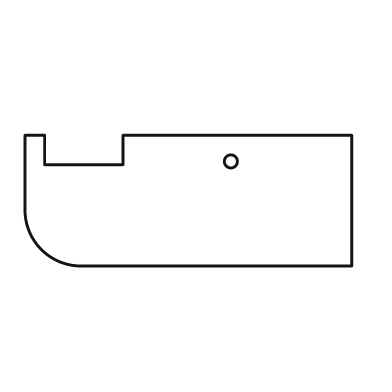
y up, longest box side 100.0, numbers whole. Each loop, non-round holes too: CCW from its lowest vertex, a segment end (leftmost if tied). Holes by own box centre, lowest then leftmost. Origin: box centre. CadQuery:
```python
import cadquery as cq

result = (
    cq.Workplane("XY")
    .moveTo(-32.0, -20.0)
    .lineTo(50.0, -20.0)
    .lineTo(50.0, 20.0)
    .lineTo(-20.0, 20.0)
    .lineTo(-20.0, 11.0)
    .lineTo(-44.0, 11.0)
    .lineTo(-44.0, 20.0)
    .lineTo(-50.0, 20.0)
    .lineTo(-50.0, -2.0)
    .threePointArc((-45.0, -15.0), (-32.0, -20.0))
    .close()
    .moveTo(13.0, 12.0)
    .circle(2.0)
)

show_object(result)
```